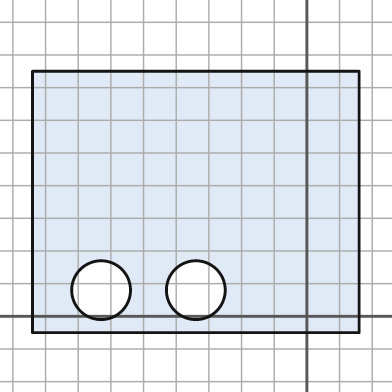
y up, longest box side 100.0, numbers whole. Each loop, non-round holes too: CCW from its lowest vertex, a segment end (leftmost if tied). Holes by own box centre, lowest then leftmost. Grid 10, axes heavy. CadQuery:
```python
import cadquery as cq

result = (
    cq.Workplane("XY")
    .moveTo(-84.0, -5.0)
    .lineTo(16.0, -5.0)
    .lineTo(16.0, 75.0)
    .lineTo(-84.0, 75.0)
    .close()
    .moveTo(-63.0, 8.0)
    .circle(9.0)
    .moveTo(-34.0, 8.0)
    .circle(9.0)
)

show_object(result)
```